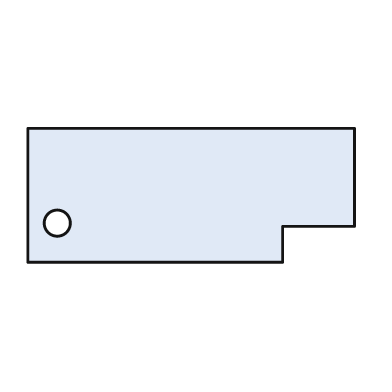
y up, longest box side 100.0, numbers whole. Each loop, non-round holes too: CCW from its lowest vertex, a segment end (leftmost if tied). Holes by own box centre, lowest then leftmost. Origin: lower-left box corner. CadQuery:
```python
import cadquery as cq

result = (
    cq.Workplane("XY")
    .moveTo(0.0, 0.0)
    .lineTo(78.0, 0.0)
    .lineTo(78.0, 11.0)
    .lineTo(100.0, 11.0)
    .lineTo(100.0, 41.0)
    .lineTo(0.0, 41.0)
    .close()
    .moveTo(9.0, 12.0)
    .circle(4.0)
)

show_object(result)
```